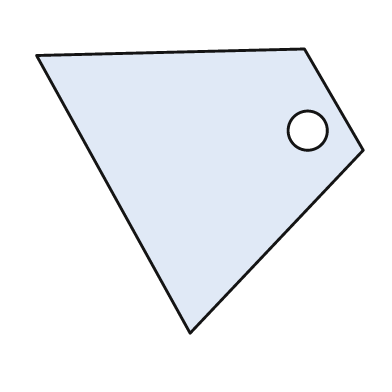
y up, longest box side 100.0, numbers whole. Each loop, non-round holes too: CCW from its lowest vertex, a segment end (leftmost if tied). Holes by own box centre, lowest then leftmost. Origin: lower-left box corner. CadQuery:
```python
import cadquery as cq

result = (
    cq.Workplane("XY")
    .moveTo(47.0, 0.0)
    .lineTo(100.0, 56.0)
    .lineTo(82.0, 87.0)
    .lineTo(0.0, 85.0)
    .close()
    .moveTo(83.0, 62.0)
    .circle(6.0)
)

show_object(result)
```